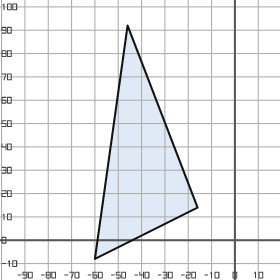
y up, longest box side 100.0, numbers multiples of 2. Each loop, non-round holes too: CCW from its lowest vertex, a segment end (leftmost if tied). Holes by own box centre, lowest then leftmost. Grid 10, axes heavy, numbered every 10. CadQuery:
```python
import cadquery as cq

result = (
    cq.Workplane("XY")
    .moveTo(-60.0, -8.0)
    .lineTo(-16.0, 14.0)
    .lineTo(-46.0, 92.0)
    .close()
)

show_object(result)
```